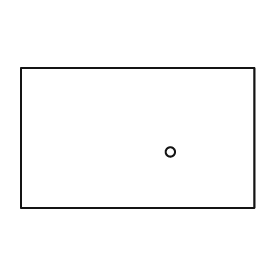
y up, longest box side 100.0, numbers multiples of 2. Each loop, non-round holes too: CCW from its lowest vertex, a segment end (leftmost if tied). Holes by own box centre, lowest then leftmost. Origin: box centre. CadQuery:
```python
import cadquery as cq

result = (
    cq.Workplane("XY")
    .moveTo(-50.0, -30.0)
    .lineTo(50.0, -30.0)
    .lineTo(50.0, 30.0)
    .lineTo(-50.0, 30.0)
    .close()
    .moveTo(14.0, -6.0)
    .circle(2.0)
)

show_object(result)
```